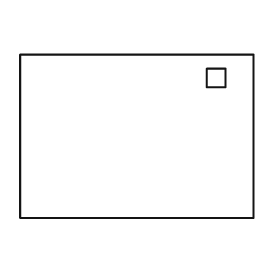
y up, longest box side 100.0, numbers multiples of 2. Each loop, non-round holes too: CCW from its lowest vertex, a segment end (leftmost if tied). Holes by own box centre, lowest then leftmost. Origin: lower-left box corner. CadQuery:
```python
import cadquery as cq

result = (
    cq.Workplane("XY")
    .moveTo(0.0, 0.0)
    .lineTo(100.0, 0.0)
    .lineTo(100.0, 70.0)
    .lineTo(0.0, 70.0)
    .close()
    .moveTo(80.0, 56.0)
    .lineTo(88.0, 56.0)
    .lineTo(88.0, 64.0)
    .lineTo(80.0, 64.0)
    .close()
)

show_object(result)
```